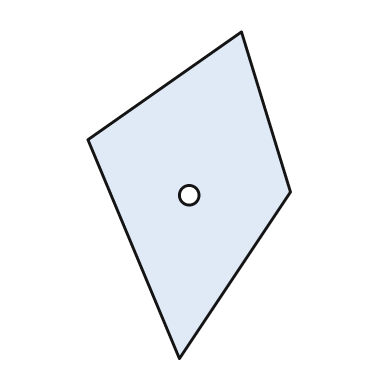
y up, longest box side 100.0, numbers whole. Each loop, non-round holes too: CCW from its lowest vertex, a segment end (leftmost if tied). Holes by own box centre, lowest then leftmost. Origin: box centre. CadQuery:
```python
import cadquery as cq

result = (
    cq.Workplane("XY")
    .moveTo(-3.0, -50.0)
    .lineTo(31.0, 1.0)
    .lineTo(16.0, 50.0)
    .lineTo(-31.0, 17.0)
    .close()
    .moveTo(0.0, 0.0)
    .circle(3.0)
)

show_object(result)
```